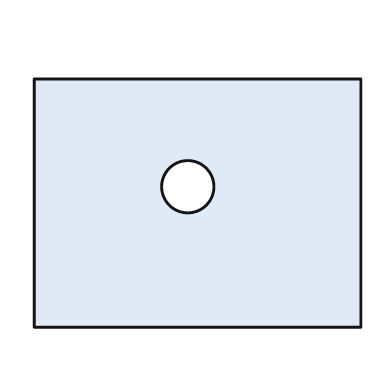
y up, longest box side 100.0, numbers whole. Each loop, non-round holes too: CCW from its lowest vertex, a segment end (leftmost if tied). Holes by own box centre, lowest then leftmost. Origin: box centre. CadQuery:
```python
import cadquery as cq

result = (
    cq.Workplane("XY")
    .moveTo(-50.0, -38.0)
    .lineTo(50.0, -38.0)
    .lineTo(50.0, 38.0)
    .lineTo(-50.0, 38.0)
    .close()
    .moveTo(-3.0, 5.0)
    .circle(8.0)
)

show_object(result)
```